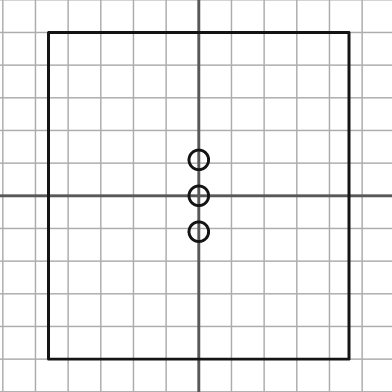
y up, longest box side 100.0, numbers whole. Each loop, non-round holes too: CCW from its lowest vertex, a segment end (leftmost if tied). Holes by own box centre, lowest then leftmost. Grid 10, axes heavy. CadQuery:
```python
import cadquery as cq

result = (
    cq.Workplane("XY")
    .moveTo(-46.0, -50.0)
    .lineTo(46.0, -50.0)
    .lineTo(46.0, 50.0)
    .lineTo(-46.0, 50.0)
    .close()
    .moveTo(0.0, -11.0)
    .circle(3.0)
    .moveTo(0.0, 0.0)
    .circle(3.0)
    .moveTo(0.0, 11.0)
    .circle(3.0)
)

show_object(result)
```